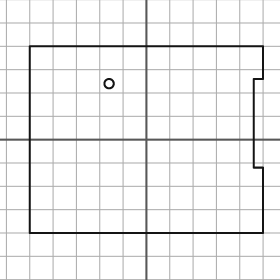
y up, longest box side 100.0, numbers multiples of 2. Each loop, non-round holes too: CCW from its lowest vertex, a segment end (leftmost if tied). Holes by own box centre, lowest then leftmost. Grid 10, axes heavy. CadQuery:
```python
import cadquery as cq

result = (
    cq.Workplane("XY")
    .moveTo(-50.0, -40.0)
    .lineTo(50.0, -40.0)
    .lineTo(50.0, -12.0)
    .lineTo(46.0, -12.0)
    .lineTo(46.0, 26.0)
    .lineTo(50.0, 26.0)
    .lineTo(50.0, 40.0)
    .lineTo(-50.0, 40.0)
    .close()
    .moveTo(-16.0, 24.0)
    .circle(2.0)
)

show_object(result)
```